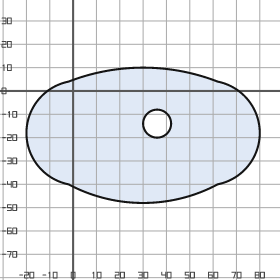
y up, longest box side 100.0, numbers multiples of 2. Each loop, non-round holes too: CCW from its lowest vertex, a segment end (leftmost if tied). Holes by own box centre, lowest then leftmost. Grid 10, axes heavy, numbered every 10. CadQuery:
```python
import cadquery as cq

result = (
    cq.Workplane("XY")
    .moveTo(-2.0, -40.0)
    .threePointArc((30.0, -48.0), (62.0, -40.0))
    .threePointArc((80.0, -18.0), (62.0, 4.0))
    .threePointArc((30.0, 10.0), (-2.0, 4.0))
    .threePointArc((-20.0, -18.0), (-2.0, -40.0))
    .close()
    .moveTo(36.0, -14.0)
    .circle(6.0)
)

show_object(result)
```